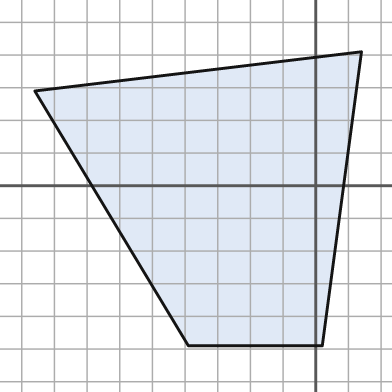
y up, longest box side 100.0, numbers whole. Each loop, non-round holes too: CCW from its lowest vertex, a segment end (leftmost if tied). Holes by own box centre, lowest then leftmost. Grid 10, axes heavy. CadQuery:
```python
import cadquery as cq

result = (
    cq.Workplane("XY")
    .moveTo(-39.0, -49.0)
    .lineTo(2.0, -49.0)
    .lineTo(14.0, 41.0)
    .lineTo(-86.0, 29.0)
    .close()
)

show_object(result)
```